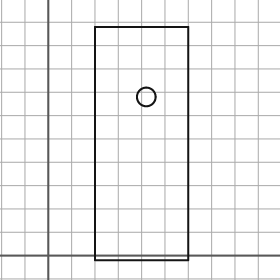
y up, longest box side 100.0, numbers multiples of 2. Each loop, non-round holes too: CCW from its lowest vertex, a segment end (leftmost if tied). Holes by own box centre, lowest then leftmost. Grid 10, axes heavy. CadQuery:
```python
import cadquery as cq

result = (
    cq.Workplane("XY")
    .moveTo(20.0, -2.0)
    .lineTo(60.0, -2.0)
    .lineTo(60.0, 98.0)
    .lineTo(20.0, 98.0)
    .close()
    .moveTo(42.0, 68.0)
    .circle(4.0)
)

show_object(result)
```